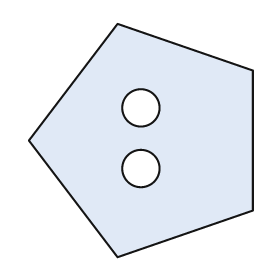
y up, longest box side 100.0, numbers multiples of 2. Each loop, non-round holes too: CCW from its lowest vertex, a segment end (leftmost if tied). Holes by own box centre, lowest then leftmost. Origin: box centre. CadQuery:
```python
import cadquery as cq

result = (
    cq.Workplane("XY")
    .moveTo(-10.0, -50.0)
    .lineTo(48.0, -30.0)
    .lineTo(48.0, 30.0)
    .lineTo(-10.0, 50.0)
    .lineTo(-48.0, 0.0)
    .close()
    .moveTo(0.0, -12.0)
    .circle(8.0)
    .moveTo(0.0, 14.0)
    .circle(8.0)
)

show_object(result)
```